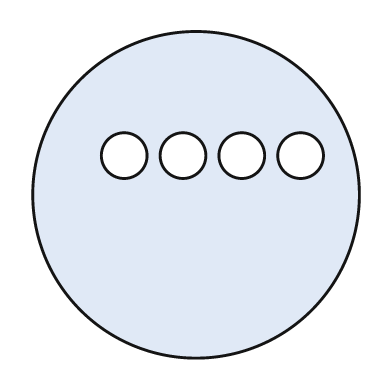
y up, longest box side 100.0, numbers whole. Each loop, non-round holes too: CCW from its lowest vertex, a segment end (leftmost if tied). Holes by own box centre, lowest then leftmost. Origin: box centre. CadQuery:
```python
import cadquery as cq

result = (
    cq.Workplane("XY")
    .moveTo(0.0, 0.0)
    .circle(50.0)
    .moveTo(-22.0, 12.0)
    .circle(7.0)
    .moveTo(-4.0, 12.0)
    .circle(7.0)
    .moveTo(14.0, 12.0)
    .circle(7.0)
    .moveTo(32.0, 12.0)
    .circle(7.0)
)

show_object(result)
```